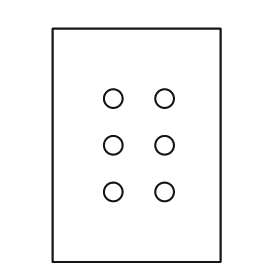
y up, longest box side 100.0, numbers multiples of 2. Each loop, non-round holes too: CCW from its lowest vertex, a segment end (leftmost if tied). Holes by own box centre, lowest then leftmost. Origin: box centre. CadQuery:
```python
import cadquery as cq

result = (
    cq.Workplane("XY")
    .moveTo(-36.0, -50.0)
    .lineTo(36.0, -50.0)
    .lineTo(36.0, 50.0)
    .lineTo(-36.0, 50.0)
    .close()
    .moveTo(-10.0, -20.0)
    .circle(4.0)
    .moveTo(12.0, -20.0)
    .circle(4.0)
    .moveTo(-10.0, 0.0)
    .circle(4.0)
    .moveTo(12.0, 0.0)
    .circle(4.0)
    .moveTo(-10.0, 20.0)
    .circle(4.0)
    .moveTo(12.0, 20.0)
    .circle(4.0)
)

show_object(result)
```